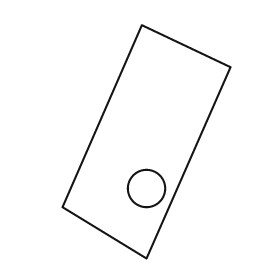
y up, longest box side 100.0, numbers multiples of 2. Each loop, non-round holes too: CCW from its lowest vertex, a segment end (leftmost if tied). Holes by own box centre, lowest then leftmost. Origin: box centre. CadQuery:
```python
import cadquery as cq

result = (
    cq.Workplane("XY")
    .moveTo(0.0, -50.0)
    .lineTo(36.0, 32.0)
    .lineTo(-2.0, 50.0)
    .lineTo(-36.0, -28.0)
    .close()
    .moveTo(0.0, -20.0)
    .circle(8.0)
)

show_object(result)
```